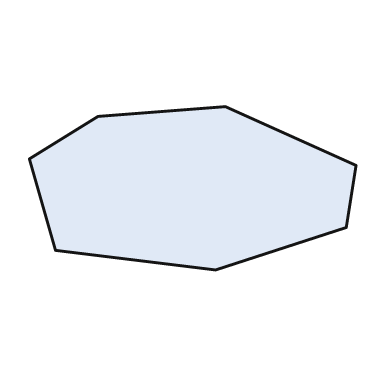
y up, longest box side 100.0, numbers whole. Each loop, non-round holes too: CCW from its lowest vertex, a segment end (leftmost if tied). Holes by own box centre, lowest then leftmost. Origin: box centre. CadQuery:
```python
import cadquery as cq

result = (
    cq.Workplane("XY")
    .moveTo(7.0, -25.0)
    .lineTo(47.0, -12.0)
    .lineTo(50.0, 7.0)
    .lineTo(10.0, 25.0)
    .lineTo(-29.0, 22.0)
    .lineTo(-50.0, 9.0)
    .lineTo(-42.0, -19.0)
    .close()
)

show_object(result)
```